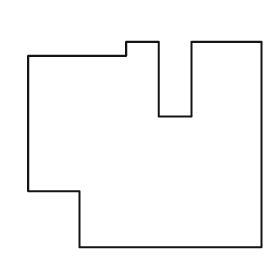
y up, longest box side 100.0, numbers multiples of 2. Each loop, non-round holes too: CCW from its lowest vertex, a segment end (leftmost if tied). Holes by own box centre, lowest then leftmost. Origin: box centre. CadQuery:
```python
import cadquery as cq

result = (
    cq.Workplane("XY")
    .moveTo(-28.0, -44.0)
    .lineTo(50.0, -44.0)
    .lineTo(50.0, 44.0)
    .lineTo(20.0, 44.0)
    .lineTo(20.0, 12.0)
    .lineTo(6.0, 12.0)
    .lineTo(6.0, 44.0)
    .lineTo(-8.0, 44.0)
    .lineTo(-8.0, 38.0)
    .lineTo(-50.0, 38.0)
    .lineTo(-50.0, -20.0)
    .lineTo(-28.0, -20.0)
    .close()
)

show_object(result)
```